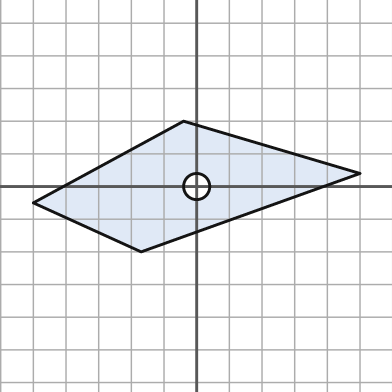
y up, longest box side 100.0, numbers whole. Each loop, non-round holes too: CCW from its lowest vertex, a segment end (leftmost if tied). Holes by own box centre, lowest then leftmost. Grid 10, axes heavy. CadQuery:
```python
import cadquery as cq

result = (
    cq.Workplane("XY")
    .moveTo(-17.0, -20.0)
    .lineTo(50.0, 4.0)
    .lineTo(-4.0, 20.0)
    .lineTo(-50.0, -5.0)
    .close()
    .moveTo(0.0, 0.0)
    .circle(4.0)
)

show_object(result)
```